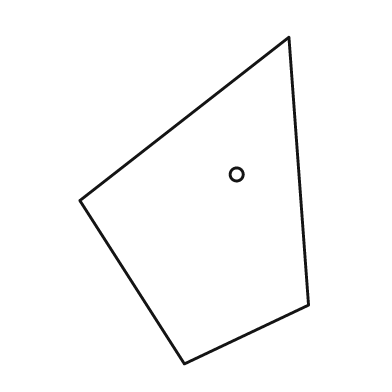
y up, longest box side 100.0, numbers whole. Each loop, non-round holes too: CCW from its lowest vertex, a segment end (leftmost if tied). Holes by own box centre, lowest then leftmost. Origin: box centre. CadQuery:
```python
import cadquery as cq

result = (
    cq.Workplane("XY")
    .moveTo(-3.0, -50.0)
    .lineTo(35.0, -32.0)
    .lineTo(29.0, 50.0)
    .lineTo(-35.0, 0.0)
    .close()
    .moveTo(13.0, 8.0)
    .circle(2.0)
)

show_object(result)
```